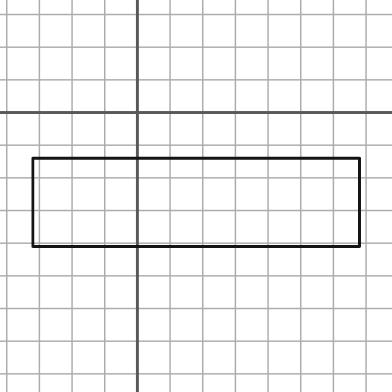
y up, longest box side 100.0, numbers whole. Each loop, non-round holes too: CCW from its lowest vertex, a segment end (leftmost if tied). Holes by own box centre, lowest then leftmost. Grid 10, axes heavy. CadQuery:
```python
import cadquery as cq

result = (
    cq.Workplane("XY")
    .moveTo(-32.0, -41.0)
    .lineTo(68.0, -41.0)
    .lineTo(68.0, -14.0)
    .lineTo(-32.0, -14.0)
    .close()
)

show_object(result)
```